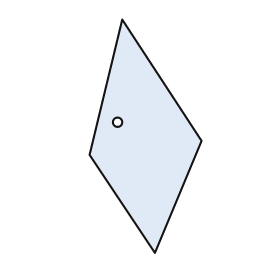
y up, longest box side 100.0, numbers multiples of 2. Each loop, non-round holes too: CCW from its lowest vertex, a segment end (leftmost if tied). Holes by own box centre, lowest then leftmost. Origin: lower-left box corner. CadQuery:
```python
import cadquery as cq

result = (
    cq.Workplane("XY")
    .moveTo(28.0, 0.0)
    .lineTo(48.0, 48.0)
    .lineTo(14.0, 100.0)
    .lineTo(0.0, 42.0)
    .close()
    .moveTo(12.0, 56.0)
    .circle(2.0)
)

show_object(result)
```